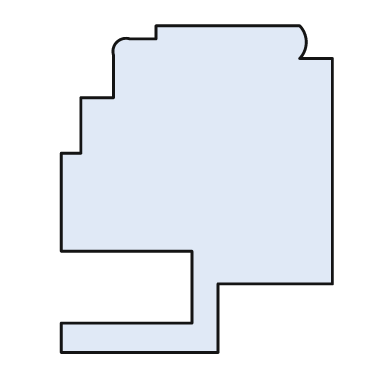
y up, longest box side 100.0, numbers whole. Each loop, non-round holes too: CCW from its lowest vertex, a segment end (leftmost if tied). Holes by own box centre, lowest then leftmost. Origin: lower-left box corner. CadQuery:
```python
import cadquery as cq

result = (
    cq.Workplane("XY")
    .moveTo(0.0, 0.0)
    .lineTo(48.0, 0.0)
    .lineTo(48.0, 21.0)
    .lineTo(83.0, 21.0)
    .lineTo(83.0, 90.0)
    .lineTo(73.0, 90.0)
    .threePointArc((75.0, 95.0), (73.0, 100.0))
    .lineTo(29.0, 100.0)
    .lineTo(29.0, 96.0)
    .lineTo(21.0, 96.0)
    .threePointArc((17.0, 95.0), (16.0, 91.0))
    .lineTo(16.0, 78.0)
    .lineTo(6.0, 78.0)
    .lineTo(6.0, 61.0)
    .lineTo(0.0, 61.0)
    .lineTo(0.0, 31.0)
    .lineTo(40.0, 31.0)
    .lineTo(40.0, 9.0)
    .lineTo(0.0, 9.0)
    .close()
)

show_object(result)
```